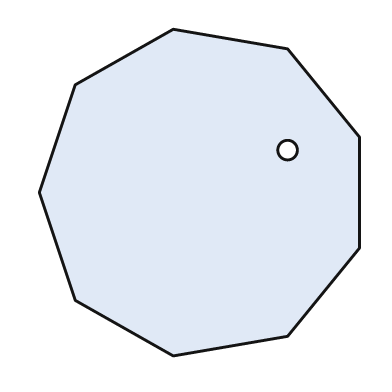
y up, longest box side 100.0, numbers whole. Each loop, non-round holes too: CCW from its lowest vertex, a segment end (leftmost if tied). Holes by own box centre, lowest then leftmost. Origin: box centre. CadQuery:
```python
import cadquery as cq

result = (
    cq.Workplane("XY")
    .moveTo(-8.0, -50.0)
    .lineTo(27.0, -44.0)
    .lineTo(49.0, -17.0)
    .lineTo(49.0, 17.0)
    .lineTo(27.0, 44.0)
    .lineTo(-8.0, 50.0)
    .lineTo(-38.0, 33.0)
    .lineTo(-49.0, 0.0)
    .lineTo(-38.0, -33.0)
    .close()
    .moveTo(27.0, 13.0)
    .circle(3.0)
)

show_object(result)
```